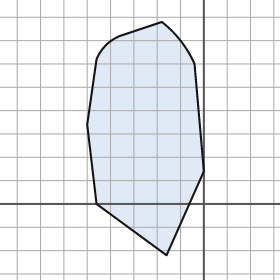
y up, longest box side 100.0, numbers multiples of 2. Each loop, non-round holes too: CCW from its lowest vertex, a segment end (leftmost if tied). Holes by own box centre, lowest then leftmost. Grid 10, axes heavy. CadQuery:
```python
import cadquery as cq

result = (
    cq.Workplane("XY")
    .moveTo(-16.0, -22.0)
    .lineTo(0.0, 14.0)
    .lineTo(-4.0, 60.0)
    .threePointArc((-10.0, 70.0), (-18.0, 78.0))
    .lineTo(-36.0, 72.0)
    .threePointArc((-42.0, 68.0), (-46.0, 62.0))
    .lineTo(-50.0, 34.0)
    .lineTo(-46.0, 0.0)
    .close()
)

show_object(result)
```